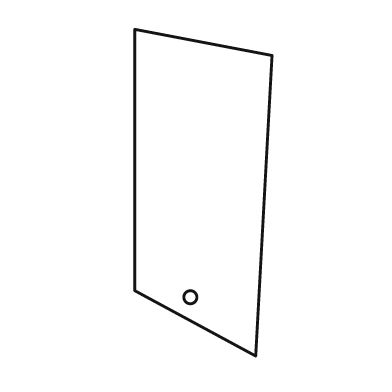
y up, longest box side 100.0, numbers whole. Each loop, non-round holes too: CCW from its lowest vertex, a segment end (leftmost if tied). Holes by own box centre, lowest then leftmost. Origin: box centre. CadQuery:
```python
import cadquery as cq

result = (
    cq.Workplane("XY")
    .moveTo(16.0, -50.0)
    .lineTo(21.0, 42.0)
    .lineTo(-21.0, 50.0)
    .lineTo(-21.0, -30.0)
    .close()
    .moveTo(-4.0, -32.0)
    .circle(2.0)
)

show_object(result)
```